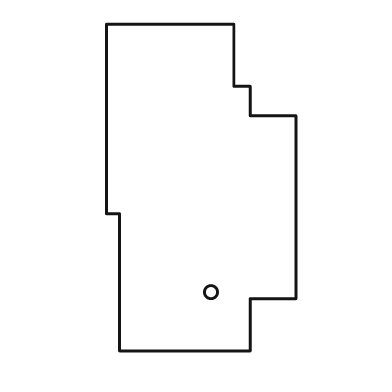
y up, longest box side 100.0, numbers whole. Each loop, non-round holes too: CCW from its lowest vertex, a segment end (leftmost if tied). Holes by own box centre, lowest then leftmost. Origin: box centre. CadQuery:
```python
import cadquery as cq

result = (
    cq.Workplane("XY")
    .moveTo(-25.0, -50.0)
    .lineTo(15.0, -50.0)
    .lineTo(15.0, -34.0)
    .lineTo(29.0, -34.0)
    .lineTo(29.0, 22.0)
    .lineTo(15.0, 22.0)
    .lineTo(15.0, 31.0)
    .lineTo(10.0, 31.0)
    .lineTo(10.0, 50.0)
    .lineTo(-29.0, 50.0)
    .lineTo(-29.0, -8.0)
    .lineTo(-25.0, -8.0)
    .close()
    .moveTo(3.0, -32.0)
    .circle(2.0)
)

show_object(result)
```